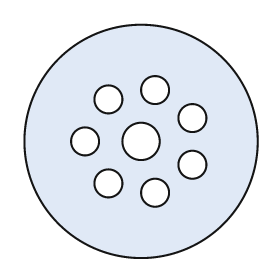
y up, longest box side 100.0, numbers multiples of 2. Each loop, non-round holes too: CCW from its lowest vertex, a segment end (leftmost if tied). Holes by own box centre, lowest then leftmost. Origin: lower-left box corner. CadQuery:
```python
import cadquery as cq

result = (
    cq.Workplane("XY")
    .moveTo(50.0, 50.0)
    .circle(50.0)
    .moveTo(56.0, 28.0)
    .circle(6.0)
    .moveTo(36.0, 32.0)
    .circle(6.0)
    .moveTo(72.0, 40.0)
    .circle(6.0)
    .moveTo(26.0, 50.0)
    .circle(6.0)
    .moveTo(50.0, 50.0)
    .circle(8.0)
    .moveTo(72.0, 60.0)
    .circle(6.0)
    .moveTo(36.0, 68.0)
    .circle(6.0)
    .moveTo(56.0, 72.0)
    .circle(6.0)
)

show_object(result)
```